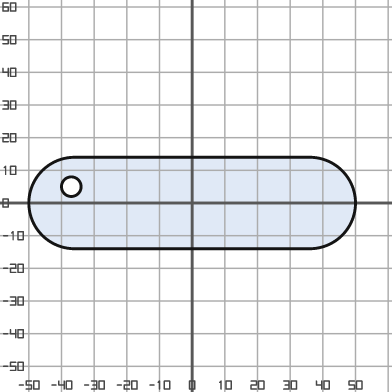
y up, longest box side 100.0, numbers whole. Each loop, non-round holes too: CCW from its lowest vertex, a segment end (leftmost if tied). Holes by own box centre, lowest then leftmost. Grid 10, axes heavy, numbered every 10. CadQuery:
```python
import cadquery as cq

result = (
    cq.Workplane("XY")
    .moveTo(-36.0, -14.0)
    .lineTo(36.0, -14.0)
    .threePointArc((50.0, 0.0), (36.0, 14.0))
    .lineTo(-36.0, 14.0)
    .threePointArc((-50.0, 0.0), (-36.0, -14.0))
    .close()
    .moveTo(-37.0, 5.0)
    .circle(3.0)
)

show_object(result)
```